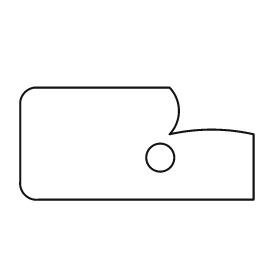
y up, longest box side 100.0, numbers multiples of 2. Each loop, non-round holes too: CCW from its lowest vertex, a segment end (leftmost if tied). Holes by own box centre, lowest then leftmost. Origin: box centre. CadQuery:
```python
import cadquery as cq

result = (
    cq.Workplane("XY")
    .moveTo(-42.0, -24.0)
    .lineTo(50.0, -24.0)
    .lineTo(50.0, 4.0)
    .threePointArc((32.0, 6.0), (14.0, 4.0))
    .threePointArc((18.0, 14.0), (14.0, 24.0))
    .lineTo(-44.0, 24.0)
    .threePointArc((-48.0, 22.0), (-50.0, 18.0))
    .lineTo(-50.0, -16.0)
    .threePointArc((-48.0, -22.0), (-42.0, -24.0))
    .close()
    .moveTo(10.0, -6.0)
    .circle(6.0)
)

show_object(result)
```